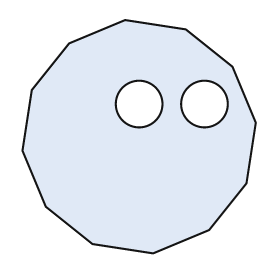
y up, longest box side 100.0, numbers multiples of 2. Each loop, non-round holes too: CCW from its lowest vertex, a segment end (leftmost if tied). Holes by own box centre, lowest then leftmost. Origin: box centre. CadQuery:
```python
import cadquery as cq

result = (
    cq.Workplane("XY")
    .moveTo(6.0, -50.0)
    .lineTo(30.0, -40.0)
    .lineTo(46.0, -20.0)
    .lineTo(50.0, 6.0)
    .lineTo(40.0, 30.0)
    .lineTo(20.0, 46.0)
    .lineTo(-6.0, 50.0)
    .lineTo(-30.0, 40.0)
    .lineTo(-46.0, 20.0)
    .lineTo(-50.0, -6.0)
    .lineTo(-40.0, -30.0)
    .lineTo(-20.0, -46.0)
    .close()
    .moveTo(0.0, 14.0)
    .circle(10.0)
    .moveTo(28.0, 14.0)
    .circle(10.0)
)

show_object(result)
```